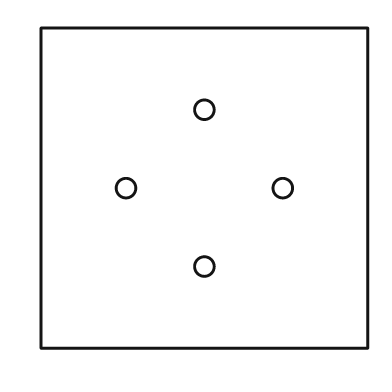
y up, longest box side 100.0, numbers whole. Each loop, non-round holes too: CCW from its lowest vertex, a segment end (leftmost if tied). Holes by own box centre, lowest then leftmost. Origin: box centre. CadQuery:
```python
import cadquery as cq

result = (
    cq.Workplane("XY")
    .moveTo(-50.0, -49.0)
    .lineTo(50.0, -49.0)
    .lineTo(50.0, 49.0)
    .lineTo(-50.0, 49.0)
    .close()
    .moveTo(0.0, -24.0)
    .circle(3.0)
    .moveTo(-24.0, 0.0)
    .circle(3.0)
    .moveTo(24.0, 0.0)
    .circle(3.0)
    .moveTo(0.0, 24.0)
    .circle(3.0)
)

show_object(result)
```